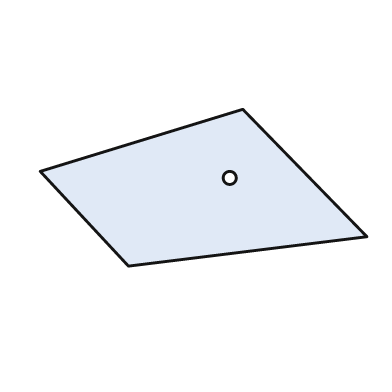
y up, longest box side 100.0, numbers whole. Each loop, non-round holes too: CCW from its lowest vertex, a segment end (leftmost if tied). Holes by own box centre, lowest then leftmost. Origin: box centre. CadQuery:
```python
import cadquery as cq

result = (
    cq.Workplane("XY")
    .moveTo(-23.0, -24.0)
    .lineTo(50.0, -15.0)
    .lineTo(12.0, 24.0)
    .lineTo(-50.0, 5.0)
    .close()
    .moveTo(8.0, 3.0)
    .circle(2.0)
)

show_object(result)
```